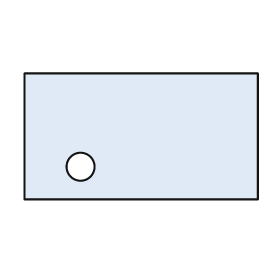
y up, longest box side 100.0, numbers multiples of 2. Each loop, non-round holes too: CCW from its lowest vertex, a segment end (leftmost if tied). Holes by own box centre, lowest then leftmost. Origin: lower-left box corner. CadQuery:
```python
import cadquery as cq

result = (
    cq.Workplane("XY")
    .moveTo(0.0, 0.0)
    .lineTo(100.0, 0.0)
    .lineTo(100.0, 54.0)
    .lineTo(0.0, 54.0)
    .close()
    .moveTo(24.0, 14.0)
    .circle(6.0)
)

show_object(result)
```